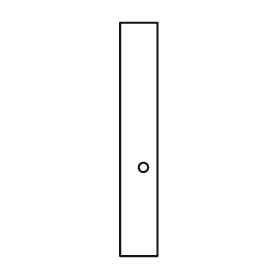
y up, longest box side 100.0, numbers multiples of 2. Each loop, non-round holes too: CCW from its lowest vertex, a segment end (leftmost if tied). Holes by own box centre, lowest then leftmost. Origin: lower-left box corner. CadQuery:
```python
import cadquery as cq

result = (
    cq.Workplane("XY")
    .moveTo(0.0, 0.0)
    .lineTo(16.0, 0.0)
    .lineTo(16.0, 100.0)
    .lineTo(0.0, 100.0)
    .close()
    .moveTo(10.0, 38.0)
    .circle(2.0)
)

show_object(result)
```